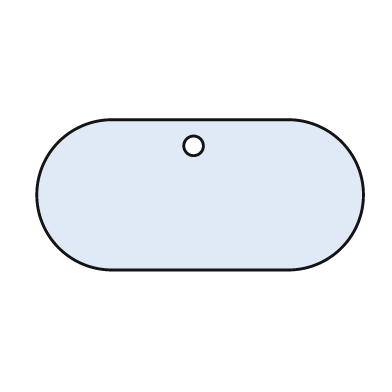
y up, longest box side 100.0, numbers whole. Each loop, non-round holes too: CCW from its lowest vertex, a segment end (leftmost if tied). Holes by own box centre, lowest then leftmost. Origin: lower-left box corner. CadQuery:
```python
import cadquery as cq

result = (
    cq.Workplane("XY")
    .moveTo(23.0, 0.0)
    .lineTo(77.0, 0.0)
    .threePointArc((100.0, 23.0), (77.0, 46.0))
    .lineTo(23.0, 46.0)
    .threePointArc((0.0, 23.0), (23.0, 0.0))
    .close()
    .moveTo(48.0, 38.0)
    .circle(3.0)
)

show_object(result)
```